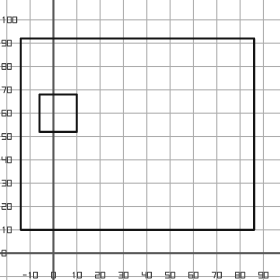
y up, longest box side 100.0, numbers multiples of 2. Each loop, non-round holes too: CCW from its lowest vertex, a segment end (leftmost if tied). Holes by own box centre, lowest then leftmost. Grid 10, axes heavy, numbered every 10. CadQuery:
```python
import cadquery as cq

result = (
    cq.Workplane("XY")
    .moveTo(-14.0, 10.0)
    .lineTo(86.0, 10.0)
    .lineTo(86.0, 92.0)
    .lineTo(-14.0, 92.0)
    .close()
    .moveTo(-6.0, 52.0)
    .lineTo(10.0, 52.0)
    .lineTo(10.0, 68.0)
    .lineTo(-6.0, 68.0)
    .close()
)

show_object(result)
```